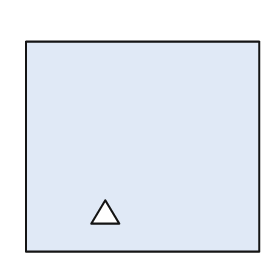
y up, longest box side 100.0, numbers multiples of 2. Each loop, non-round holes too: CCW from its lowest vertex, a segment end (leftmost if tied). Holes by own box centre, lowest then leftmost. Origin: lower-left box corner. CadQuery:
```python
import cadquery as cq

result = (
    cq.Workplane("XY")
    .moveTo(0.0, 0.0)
    .lineTo(100.0, 0.0)
    .lineTo(100.0, 90.0)
    .lineTo(0.0, 90.0)
    .close()
    .moveTo(28.0, 12.0)
    .lineTo(40.0, 12.0)
    .lineTo(34.0, 22.0)
    .close()
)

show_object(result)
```